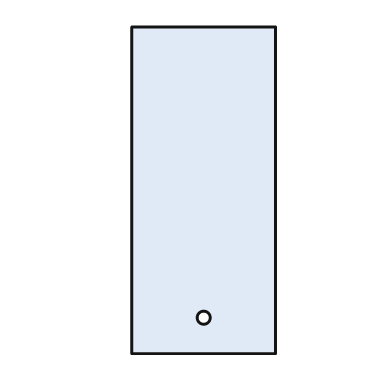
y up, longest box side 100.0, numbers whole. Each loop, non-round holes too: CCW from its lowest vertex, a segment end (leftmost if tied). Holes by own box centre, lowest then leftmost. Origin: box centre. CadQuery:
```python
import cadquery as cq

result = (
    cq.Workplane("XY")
    .moveTo(-22.0, -50.0)
    .lineTo(22.0, -50.0)
    .lineTo(22.0, 50.0)
    .lineTo(-22.0, 50.0)
    .close()
    .moveTo(0.0, -39.0)
    .circle(2.0)
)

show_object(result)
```